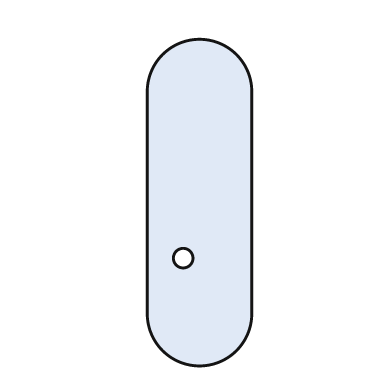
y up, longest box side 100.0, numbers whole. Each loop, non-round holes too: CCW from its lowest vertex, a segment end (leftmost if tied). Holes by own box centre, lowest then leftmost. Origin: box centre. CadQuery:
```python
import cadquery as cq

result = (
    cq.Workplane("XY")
    .moveTo(-16.0, -34.0)
    .threePointArc((0.0, -50.0), (16.0, -34.0))
    .lineTo(16.0, 34.0)
    .threePointArc((0.0, 50.0), (-16.0, 34.0))
    .close()
    .moveTo(-5.0, -17.0)
    .circle(3.0)
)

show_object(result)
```